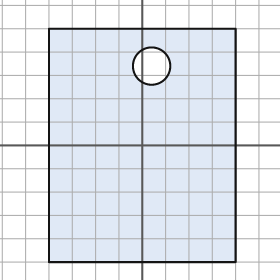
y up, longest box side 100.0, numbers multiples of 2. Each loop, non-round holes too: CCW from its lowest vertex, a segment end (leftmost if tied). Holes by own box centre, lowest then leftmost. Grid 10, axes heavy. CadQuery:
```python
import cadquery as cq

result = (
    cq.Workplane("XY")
    .moveTo(-40.0, -50.0)
    .lineTo(40.0, -50.0)
    .lineTo(40.0, 50.0)
    .lineTo(-40.0, 50.0)
    .close()
    .moveTo(4.0, 34.0)
    .circle(8.0)
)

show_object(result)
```